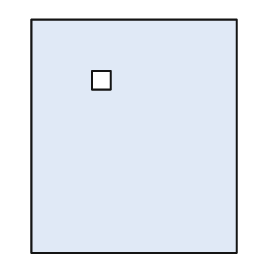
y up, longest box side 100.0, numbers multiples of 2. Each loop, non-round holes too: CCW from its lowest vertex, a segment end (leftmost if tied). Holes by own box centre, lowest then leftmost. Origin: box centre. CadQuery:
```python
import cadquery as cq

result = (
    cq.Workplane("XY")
    .moveTo(-44.0, -50.0)
    .lineTo(44.0, -50.0)
    .lineTo(44.0, 50.0)
    .lineTo(-44.0, 50.0)
    .close()
    .moveTo(-18.0, 20.0)
    .lineTo(-10.0, 20.0)
    .lineTo(-10.0, 28.0)
    .lineTo(-18.0, 28.0)
    .close()
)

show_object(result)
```